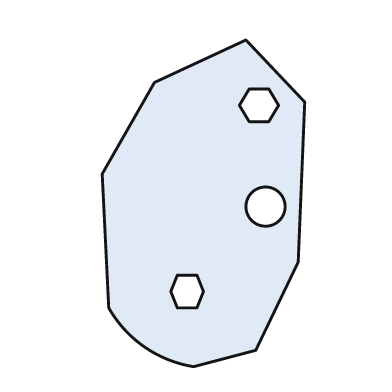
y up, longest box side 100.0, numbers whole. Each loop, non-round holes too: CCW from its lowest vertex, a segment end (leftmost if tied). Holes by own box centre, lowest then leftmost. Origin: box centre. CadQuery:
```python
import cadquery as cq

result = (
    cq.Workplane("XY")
    .moveTo(-3.0, -50.0)
    .lineTo(16.0, -45.0)
    .lineTo(29.0, -18.0)
    .lineTo(31.0, 31.0)
    .lineTo(13.0, 50.0)
    .lineTo(-15.0, 37.0)
    .lineTo(-31.0, 9.0)
    .lineTo(-29.0, -32.0)
    .threePointArc((-18.0, -44.0), (-3.0, -50.0))
    .close()
    .moveTo(-8.0, -32.0)
    .lineTo(-2.0, -32.0)
    .lineTo(0.0, -27.0)
    .lineTo(-2.0, -22.0)
    .lineTo(-8.0, -22.0)
    .lineTo(-10.0, -27.0)
    .close()
    .moveTo(19.0, -1.0)
    .circle(6.0)
    .moveTo(14.0, 25.0)
    .lineTo(20.0, 25.0)
    .lineTo(23.0, 30.0)
    .lineTo(20.0, 35.0)
    .lineTo(14.0, 35.0)
    .lineTo(11.0, 30.0)
    .close()
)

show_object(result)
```